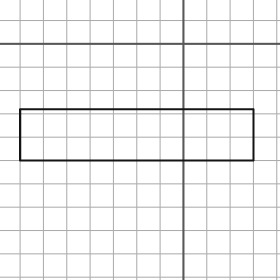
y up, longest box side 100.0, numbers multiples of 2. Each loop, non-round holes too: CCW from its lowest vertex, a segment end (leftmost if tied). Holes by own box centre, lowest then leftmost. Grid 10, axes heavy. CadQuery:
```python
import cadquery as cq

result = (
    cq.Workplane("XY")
    .moveTo(-70.0, -50.0)
    .lineTo(30.0, -50.0)
    .lineTo(30.0, -28.0)
    .lineTo(-70.0, -28.0)
    .close()
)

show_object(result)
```